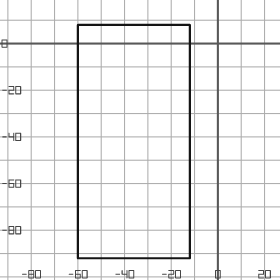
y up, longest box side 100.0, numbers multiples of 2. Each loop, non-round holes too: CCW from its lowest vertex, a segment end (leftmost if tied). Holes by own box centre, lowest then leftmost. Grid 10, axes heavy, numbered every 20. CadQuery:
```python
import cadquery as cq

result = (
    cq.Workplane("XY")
    .moveTo(-60.0, -92.0)
    .lineTo(-12.0, -92.0)
    .lineTo(-12.0, 8.0)
    .lineTo(-60.0, 8.0)
    .close()
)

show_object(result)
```